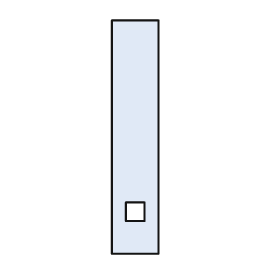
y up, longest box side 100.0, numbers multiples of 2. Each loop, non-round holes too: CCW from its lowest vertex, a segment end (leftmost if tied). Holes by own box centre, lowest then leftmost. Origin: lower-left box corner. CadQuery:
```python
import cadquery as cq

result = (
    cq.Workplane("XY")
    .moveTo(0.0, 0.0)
    .lineTo(20.0, 0.0)
    .lineTo(20.0, 100.0)
    .lineTo(0.0, 100.0)
    .close()
    .moveTo(6.0, 14.0)
    .lineTo(14.0, 14.0)
    .lineTo(14.0, 22.0)
    .lineTo(6.0, 22.0)
    .close()
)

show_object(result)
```